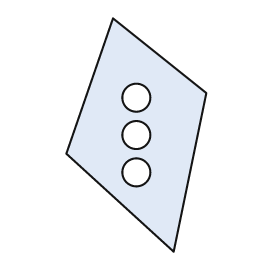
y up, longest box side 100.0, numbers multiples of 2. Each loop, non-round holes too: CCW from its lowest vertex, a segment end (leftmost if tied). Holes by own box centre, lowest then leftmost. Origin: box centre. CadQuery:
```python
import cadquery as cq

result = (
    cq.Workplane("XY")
    .moveTo(16.0, -50.0)
    .lineTo(30.0, 18.0)
    .lineTo(-10.0, 50.0)
    .lineTo(-30.0, -8.0)
    .close()
    .moveTo(0.0, -16.0)
    .circle(6.0)
    .moveTo(0.0, 0.0)
    .circle(6.0)
    .moveTo(0.0, 16.0)
    .circle(6.0)
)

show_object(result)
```